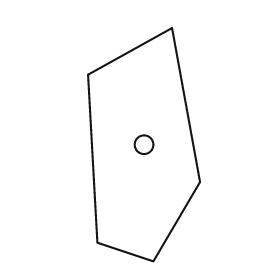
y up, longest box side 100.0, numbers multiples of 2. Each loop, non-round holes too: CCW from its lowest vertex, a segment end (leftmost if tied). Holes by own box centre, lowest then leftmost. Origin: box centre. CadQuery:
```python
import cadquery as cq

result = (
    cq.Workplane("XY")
    .moveTo(4.0, -50.0)
    .lineTo(24.0, -16.0)
    .lineTo(12.0, 50.0)
    .lineTo(-24.0, 30.0)
    .lineTo(-20.0, -42.0)
    .close()
    .moveTo(0.0, 0.0)
    .circle(4.0)
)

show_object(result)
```